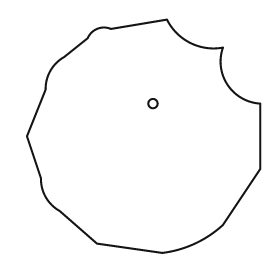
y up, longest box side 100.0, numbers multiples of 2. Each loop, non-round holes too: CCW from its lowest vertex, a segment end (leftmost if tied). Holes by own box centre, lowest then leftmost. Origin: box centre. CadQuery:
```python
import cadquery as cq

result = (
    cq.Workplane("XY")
    .moveTo(8.0, -50.0)
    .threePointArc((22.0, -46.0), (34.0, -38.0))
    .lineTo(50.0, -14.0)
    .lineTo(50.0, 14.0)
    .threePointArc((36.0, 22.0), (34.0, 38.0))
    .threePointArc((20.0, 40.0), (10.0, 50.0))
    .lineTo(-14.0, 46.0)
    .threePointArc((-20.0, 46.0), (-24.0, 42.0))
    .lineTo(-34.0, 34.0)
    .threePointArc((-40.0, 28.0), (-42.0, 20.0))
    .lineTo(-50.0, 0.0)
    .lineTo(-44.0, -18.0)
    .threePointArc((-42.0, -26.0), (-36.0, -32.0))
    .lineTo(-20.0, -46.0)
    .close()
    .moveTo(4.0, 14.0)
    .circle(2.0)
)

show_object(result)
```